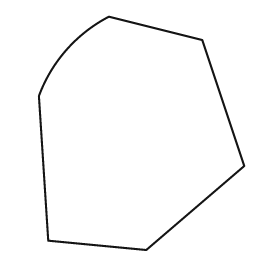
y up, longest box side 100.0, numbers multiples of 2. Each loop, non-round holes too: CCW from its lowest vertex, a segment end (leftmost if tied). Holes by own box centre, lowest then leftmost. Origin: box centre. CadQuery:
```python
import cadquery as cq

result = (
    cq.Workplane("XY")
    .moveTo(2.0, -50.0)
    .lineTo(44.0, -14.0)
    .lineTo(26.0, 40.0)
    .lineTo(-14.0, 50.0)
    .threePointArc((-32.0, 36.0), (-44.0, 16.0))
    .lineTo(-40.0, -46.0)
    .close()
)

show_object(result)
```